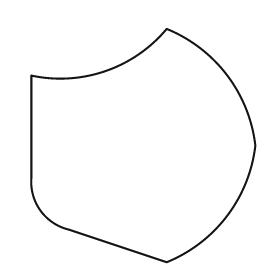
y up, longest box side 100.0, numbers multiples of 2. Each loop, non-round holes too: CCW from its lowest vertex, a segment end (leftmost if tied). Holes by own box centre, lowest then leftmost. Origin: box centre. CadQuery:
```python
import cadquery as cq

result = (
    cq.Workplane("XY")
    .moveTo(10.0, -50.0)
    .threePointArc((36.0, -30.0), (48.0, 0.0))
    .threePointArc((36.0, 30.0), (10.0, 50.0))
    .threePointArc((-16.0, 32.0), (-48.0, 30.0))
    .lineTo(-48.0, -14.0)
    .threePointArc((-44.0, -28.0), (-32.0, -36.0))
    .close()
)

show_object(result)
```